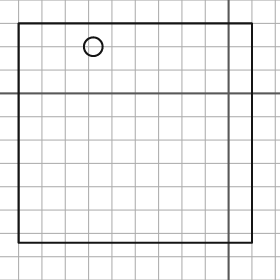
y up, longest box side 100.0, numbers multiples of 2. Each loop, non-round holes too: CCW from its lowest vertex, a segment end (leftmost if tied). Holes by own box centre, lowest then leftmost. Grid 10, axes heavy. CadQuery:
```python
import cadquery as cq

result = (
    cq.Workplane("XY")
    .moveTo(-90.0, -64.0)
    .lineTo(10.0, -64.0)
    .lineTo(10.0, 30.0)
    .lineTo(-90.0, 30.0)
    .close()
    .moveTo(-58.0, 20.0)
    .circle(4.0)
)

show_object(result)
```